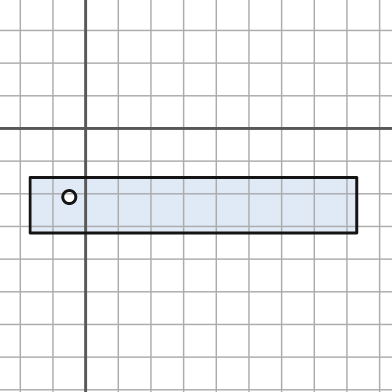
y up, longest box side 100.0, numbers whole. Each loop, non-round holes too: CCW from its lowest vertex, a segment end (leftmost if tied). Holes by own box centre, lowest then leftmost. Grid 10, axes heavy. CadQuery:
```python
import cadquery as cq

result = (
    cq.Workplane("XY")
    .moveTo(-17.0, -32.0)
    .lineTo(83.0, -32.0)
    .lineTo(83.0, -15.0)
    .lineTo(-17.0, -15.0)
    .close()
    .moveTo(-5.0, -21.0)
    .circle(2.0)
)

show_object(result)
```